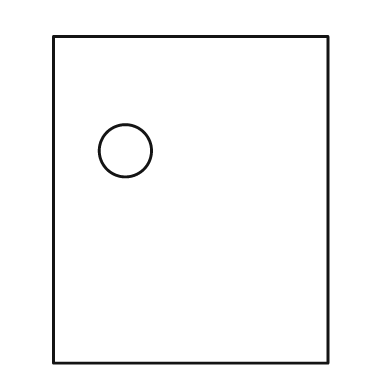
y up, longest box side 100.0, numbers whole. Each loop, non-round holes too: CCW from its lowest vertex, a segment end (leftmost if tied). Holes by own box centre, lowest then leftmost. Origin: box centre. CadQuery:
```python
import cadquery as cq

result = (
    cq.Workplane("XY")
    .moveTo(-42.0, -50.0)
    .lineTo(42.0, -50.0)
    .lineTo(42.0, 50.0)
    .lineTo(-42.0, 50.0)
    .close()
    .moveTo(-20.0, 15.0)
    .circle(8.0)
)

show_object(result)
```